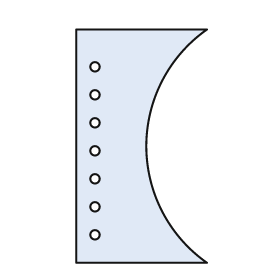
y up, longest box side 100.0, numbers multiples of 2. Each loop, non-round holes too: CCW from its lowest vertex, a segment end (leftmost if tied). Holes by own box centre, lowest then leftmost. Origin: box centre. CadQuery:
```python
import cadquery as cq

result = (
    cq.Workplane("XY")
    .moveTo(-28.0, -50.0)
    .lineTo(28.0, -50.0)
    .threePointArc((2.0, 0.0), (28.0, 50.0))
    .lineTo(-28.0, 50.0)
    .close()
    .moveTo(-20.0, -38.0)
    .circle(2.0)
    .moveTo(-20.0, -26.0)
    .circle(2.0)
    .moveTo(-20.0, -14.0)
    .circle(2.0)
    .moveTo(-20.0, -2.0)
    .circle(2.0)
    .moveTo(-20.0, 10.0)
    .circle(2.0)
    .moveTo(-20.0, 22.0)
    .circle(2.0)
    .moveTo(-20.0, 34.0)
    .circle(2.0)
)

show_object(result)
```